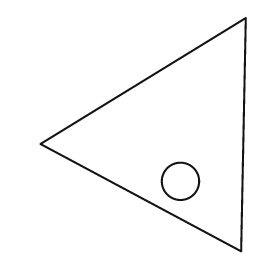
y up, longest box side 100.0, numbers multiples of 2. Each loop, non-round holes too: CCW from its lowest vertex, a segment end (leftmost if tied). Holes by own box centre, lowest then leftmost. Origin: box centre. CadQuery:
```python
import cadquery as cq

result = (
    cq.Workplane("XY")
    .moveTo(42.0, -50.0)
    .lineTo(44.0, 50.0)
    .lineTo(-44.0, -4.0)
    .close()
    .moveTo(16.0, -20.0)
    .circle(8.0)
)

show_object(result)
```